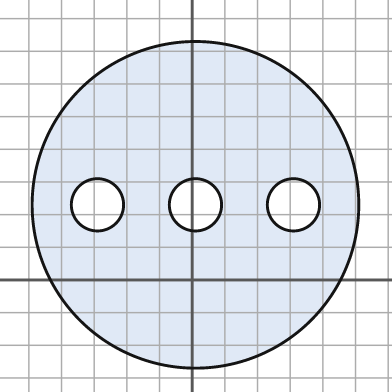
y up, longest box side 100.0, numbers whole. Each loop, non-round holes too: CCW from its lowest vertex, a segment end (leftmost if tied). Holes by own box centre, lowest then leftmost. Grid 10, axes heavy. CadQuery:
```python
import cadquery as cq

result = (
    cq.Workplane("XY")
    .moveTo(1.0, 23.0)
    .circle(50.0)
    .moveTo(-29.0, 23.0)
    .circle(8.0)
    .moveTo(1.0, 23.0)
    .circle(8.0)
    .moveTo(31.0, 23.0)
    .circle(8.0)
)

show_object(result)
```